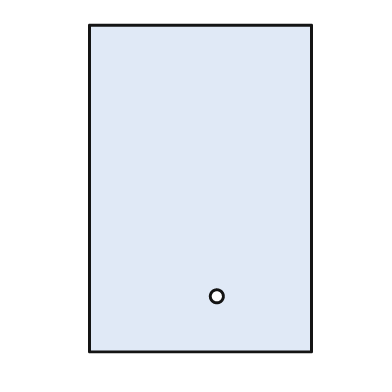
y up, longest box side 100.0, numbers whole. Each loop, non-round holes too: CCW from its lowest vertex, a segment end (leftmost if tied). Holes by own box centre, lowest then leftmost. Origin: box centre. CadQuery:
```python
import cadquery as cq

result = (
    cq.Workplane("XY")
    .moveTo(-34.0, -50.0)
    .lineTo(34.0, -50.0)
    .lineTo(34.0, 50.0)
    .lineTo(-34.0, 50.0)
    .close()
    .moveTo(5.0, -33.0)
    .circle(2.0)
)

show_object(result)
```